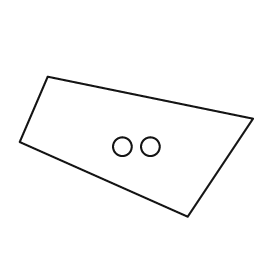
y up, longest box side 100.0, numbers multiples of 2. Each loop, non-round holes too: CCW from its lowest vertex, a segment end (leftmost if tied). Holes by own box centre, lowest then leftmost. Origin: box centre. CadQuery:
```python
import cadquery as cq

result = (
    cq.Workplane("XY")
    .moveTo(22.0, -30.0)
    .lineTo(50.0, 12.0)
    .lineTo(-38.0, 30.0)
    .lineTo(-50.0, 2.0)
    .close()
    .moveTo(-6.0, 0.0)
    .circle(4.0)
    .moveTo(6.0, 0.0)
    .circle(4.0)
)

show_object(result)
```